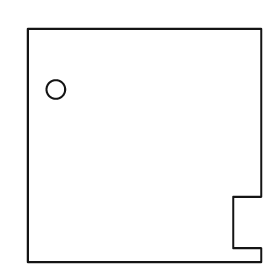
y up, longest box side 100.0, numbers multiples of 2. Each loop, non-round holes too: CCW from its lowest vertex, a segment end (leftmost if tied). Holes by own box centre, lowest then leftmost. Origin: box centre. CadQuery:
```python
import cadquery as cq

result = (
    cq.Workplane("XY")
    .moveTo(-50.0, -50.0)
    .lineTo(50.0, -50.0)
    .lineTo(50.0, -44.0)
    .lineTo(38.0, -44.0)
    .lineTo(38.0, -22.0)
    .lineTo(50.0, -22.0)
    .lineTo(50.0, 50.0)
    .lineTo(-50.0, 50.0)
    .close()
    .moveTo(-38.0, 24.0)
    .circle(4.0)
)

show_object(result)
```